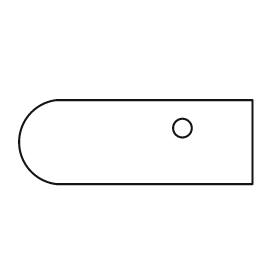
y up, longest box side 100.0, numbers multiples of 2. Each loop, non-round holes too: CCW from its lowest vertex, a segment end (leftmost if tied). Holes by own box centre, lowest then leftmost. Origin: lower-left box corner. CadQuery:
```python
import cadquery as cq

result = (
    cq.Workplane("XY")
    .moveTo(16.0, 0.0)
    .lineTo(100.0, 0.0)
    .lineTo(100.0, 36.0)
    .lineTo(16.0, 36.0)
    .threePointArc((0.0, 18.0), (16.0, 0.0))
    .close()
    .moveTo(70.0, 24.0)
    .circle(4.0)
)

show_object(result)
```